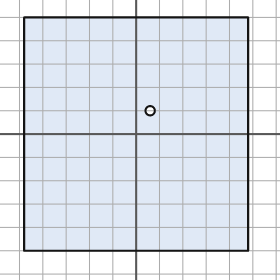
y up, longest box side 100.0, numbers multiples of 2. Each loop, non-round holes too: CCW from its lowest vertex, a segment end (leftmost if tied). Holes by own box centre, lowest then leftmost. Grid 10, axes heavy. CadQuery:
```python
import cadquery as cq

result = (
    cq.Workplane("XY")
    .moveTo(-48.0, -50.0)
    .lineTo(48.0, -50.0)
    .lineTo(48.0, 50.0)
    .lineTo(-48.0, 50.0)
    .close()
    .moveTo(6.0, 10.0)
    .circle(2.0)
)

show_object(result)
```